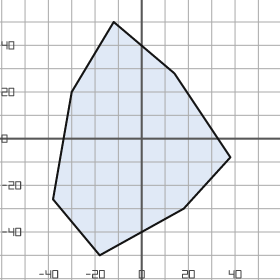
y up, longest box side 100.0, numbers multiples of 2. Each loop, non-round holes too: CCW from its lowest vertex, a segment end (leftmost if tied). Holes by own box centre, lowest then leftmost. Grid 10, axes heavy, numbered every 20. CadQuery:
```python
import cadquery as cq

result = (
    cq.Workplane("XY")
    .moveTo(-18.0, -50.0)
    .lineTo(18.0, -30.0)
    .lineTo(38.0, -8.0)
    .lineTo(14.0, 28.0)
    .lineTo(-12.0, 50.0)
    .lineTo(-30.0, 20.0)
    .lineTo(-38.0, -26.0)
    .close()
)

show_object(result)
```